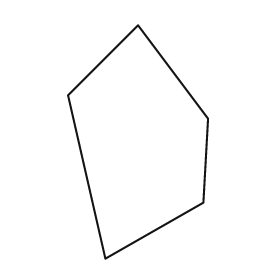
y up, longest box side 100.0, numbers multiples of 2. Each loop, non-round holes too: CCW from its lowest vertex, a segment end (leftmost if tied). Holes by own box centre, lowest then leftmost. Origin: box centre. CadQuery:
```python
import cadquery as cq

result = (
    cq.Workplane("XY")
    .moveTo(-14.0, -50.0)
    .lineTo(28.0, -26.0)
    .lineTo(30.0, 10.0)
    .lineTo(0.0, 50.0)
    .lineTo(-30.0, 20.0)
    .close()
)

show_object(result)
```